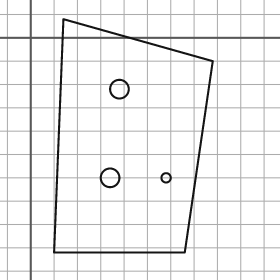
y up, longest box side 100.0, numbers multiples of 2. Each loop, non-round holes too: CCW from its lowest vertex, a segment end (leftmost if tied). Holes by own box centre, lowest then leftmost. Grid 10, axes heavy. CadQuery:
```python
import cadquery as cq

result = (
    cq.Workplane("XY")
    .moveTo(10.0, -92.0)
    .lineTo(66.0, -92.0)
    .lineTo(78.0, -10.0)
    .lineTo(14.0, 8.0)
    .close()
    .moveTo(34.0, -60.0)
    .circle(4.0)
    .moveTo(58.0, -60.0)
    .circle(2.0)
    .moveTo(38.0, -22.0)
    .circle(4.0)
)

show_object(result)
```